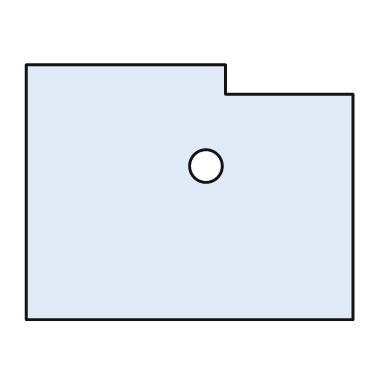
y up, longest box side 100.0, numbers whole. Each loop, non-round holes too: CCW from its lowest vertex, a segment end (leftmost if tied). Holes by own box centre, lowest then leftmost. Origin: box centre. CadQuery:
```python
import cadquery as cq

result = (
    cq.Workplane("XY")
    .moveTo(-50.0, -39.0)
    .lineTo(50.0, -39.0)
    .lineTo(50.0, 30.0)
    .lineTo(11.0, 30.0)
    .lineTo(11.0, 39.0)
    .lineTo(-50.0, 39.0)
    .close()
    .moveTo(5.0, 8.0)
    .circle(5.0)
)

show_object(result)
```